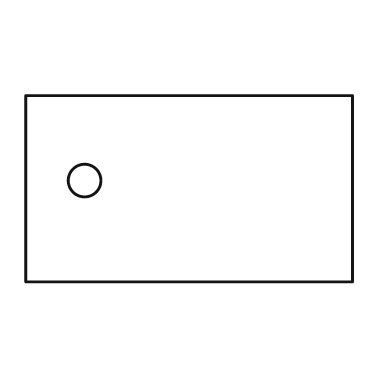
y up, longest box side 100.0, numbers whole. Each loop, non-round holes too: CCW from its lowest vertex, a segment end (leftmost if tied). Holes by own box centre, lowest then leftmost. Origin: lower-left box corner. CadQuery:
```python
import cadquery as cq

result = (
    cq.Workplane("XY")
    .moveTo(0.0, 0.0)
    .lineTo(100.0, 0.0)
    .lineTo(100.0, 57.0)
    .lineTo(0.0, 57.0)
    .close()
    .moveTo(18.0, 31.0)
    .circle(5.0)
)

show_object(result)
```